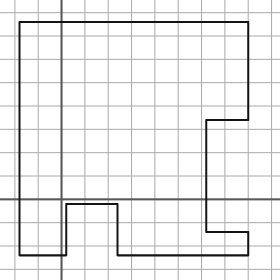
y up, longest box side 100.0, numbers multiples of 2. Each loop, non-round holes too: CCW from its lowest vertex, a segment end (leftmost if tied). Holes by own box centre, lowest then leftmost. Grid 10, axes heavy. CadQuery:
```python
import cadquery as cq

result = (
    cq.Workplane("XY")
    .moveTo(-18.0, -24.0)
    .lineTo(2.0, -24.0)
    .lineTo(2.0, -2.0)
    .lineTo(24.0, -2.0)
    .lineTo(24.0, -24.0)
    .lineTo(80.0, -24.0)
    .lineTo(80.0, -14.0)
    .lineTo(62.0, -14.0)
    .lineTo(62.0, 34.0)
    .lineTo(80.0, 34.0)
    .lineTo(80.0, 76.0)
    .lineTo(-18.0, 76.0)
    .close()
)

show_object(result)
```